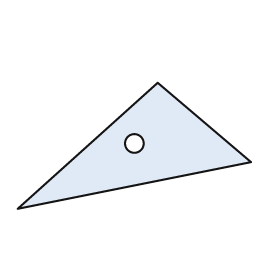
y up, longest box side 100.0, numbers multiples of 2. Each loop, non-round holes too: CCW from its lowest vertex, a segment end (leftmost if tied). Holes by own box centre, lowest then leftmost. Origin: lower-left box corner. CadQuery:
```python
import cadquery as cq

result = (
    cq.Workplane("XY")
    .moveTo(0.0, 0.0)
    .lineTo(100.0, 20.0)
    .lineTo(60.0, 54.0)
    .close()
    .moveTo(50.0, 28.0)
    .circle(4.0)
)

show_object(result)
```